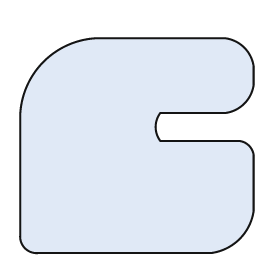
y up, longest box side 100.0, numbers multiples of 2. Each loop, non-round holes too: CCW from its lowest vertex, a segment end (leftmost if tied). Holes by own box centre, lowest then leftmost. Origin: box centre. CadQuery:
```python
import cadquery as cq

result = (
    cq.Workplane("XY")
    .moveTo(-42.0, -46.0)
    .lineTo(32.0, -46.0)
    .threePointArc((44.0, -40.0), (50.0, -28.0))
    .lineTo(50.0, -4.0)
    .threePointArc((48.0, 0.0), (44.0, 2.0))
    .lineTo(10.0, 2.0)
    .threePointArc((8.0, 8.0), (10.0, 14.0))
    .lineTo(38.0, 14.0)
    .threePointArc((46.0, 18.0), (50.0, 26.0))
    .lineTo(50.0, 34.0)
    .threePointArc((46.0, 42.0), (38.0, 46.0))
    .lineTo(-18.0, 46.0)
    .threePointArc((-40.0, 36.0), (-50.0, 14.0))
    .lineTo(-50.0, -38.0)
    .threePointArc((-48.0, -44.0), (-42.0, -46.0))
    .close()
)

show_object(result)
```